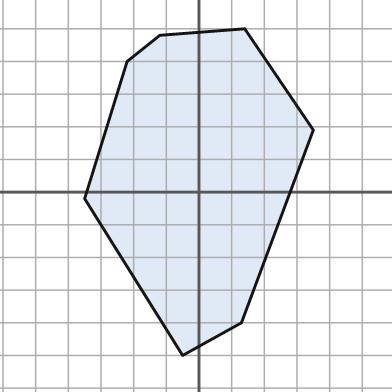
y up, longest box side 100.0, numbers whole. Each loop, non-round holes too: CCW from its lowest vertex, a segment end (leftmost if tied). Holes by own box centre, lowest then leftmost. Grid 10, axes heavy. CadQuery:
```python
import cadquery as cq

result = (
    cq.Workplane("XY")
    .moveTo(-5.0, -50.0)
    .lineTo(13.0, -40.0)
    .lineTo(35.0, 19.0)
    .lineTo(14.0, 50.0)
    .lineTo(-12.0, 48.0)
    .lineTo(-22.0, 40.0)
    .lineTo(-35.0, -2.0)
    .close()
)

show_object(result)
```